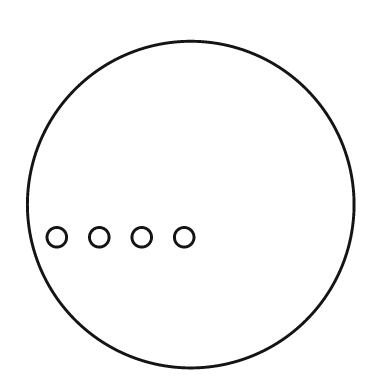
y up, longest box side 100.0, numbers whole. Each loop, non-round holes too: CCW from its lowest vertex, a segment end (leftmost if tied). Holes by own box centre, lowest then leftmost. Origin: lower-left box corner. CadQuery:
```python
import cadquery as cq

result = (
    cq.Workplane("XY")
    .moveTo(50.0, 50.0)
    .circle(50.0)
    .moveTo(9.0, 40.0)
    .circle(3.0)
    .moveTo(22.0, 40.0)
    .circle(3.0)
    .moveTo(35.0, 40.0)
    .circle(3.0)
    .moveTo(48.0, 40.0)
    .circle(3.0)
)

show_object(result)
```